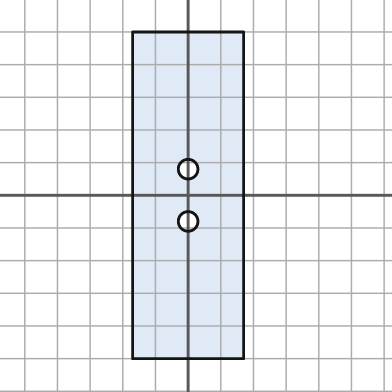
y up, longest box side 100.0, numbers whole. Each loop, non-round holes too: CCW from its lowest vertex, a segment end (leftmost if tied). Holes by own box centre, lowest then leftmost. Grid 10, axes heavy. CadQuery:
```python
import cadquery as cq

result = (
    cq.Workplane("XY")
    .moveTo(-17.0, -50.0)
    .lineTo(17.0, -50.0)
    .lineTo(17.0, 50.0)
    .lineTo(-17.0, 50.0)
    .close()
    .moveTo(0.0, -8.0)
    .circle(3.0)
    .moveTo(0.0, 8.0)
    .circle(3.0)
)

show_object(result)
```